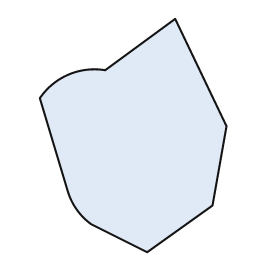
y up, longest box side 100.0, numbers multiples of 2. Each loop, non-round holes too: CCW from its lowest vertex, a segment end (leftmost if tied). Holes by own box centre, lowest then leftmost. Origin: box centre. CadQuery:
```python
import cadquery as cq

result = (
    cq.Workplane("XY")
    .moveTo(6.0, -50.0)
    .lineTo(34.0, -30.0)
    .lineTo(40.0, 4.0)
    .lineTo(18.0, 50.0)
    .lineTo(-12.0, 28.0)
    .threePointArc((-28.0, 26.0), (-40.0, 16.0))
    .lineTo(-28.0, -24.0)
    .threePointArc((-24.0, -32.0), (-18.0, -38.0))
    .close()
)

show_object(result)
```